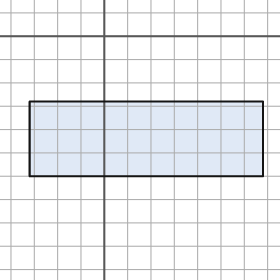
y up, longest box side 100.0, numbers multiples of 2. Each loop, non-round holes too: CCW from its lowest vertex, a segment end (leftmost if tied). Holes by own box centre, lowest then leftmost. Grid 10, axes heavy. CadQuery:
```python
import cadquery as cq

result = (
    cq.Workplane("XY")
    .moveTo(-32.0, -60.0)
    .lineTo(68.0, -60.0)
    .lineTo(68.0, -28.0)
    .lineTo(-32.0, -28.0)
    .close()
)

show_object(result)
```